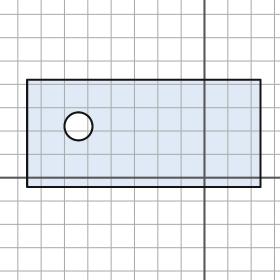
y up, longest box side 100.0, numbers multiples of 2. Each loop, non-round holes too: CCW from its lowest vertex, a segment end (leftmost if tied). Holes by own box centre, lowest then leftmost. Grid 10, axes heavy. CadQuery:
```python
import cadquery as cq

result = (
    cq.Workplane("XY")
    .moveTo(-76.0, -4.0)
    .lineTo(24.0, -4.0)
    .lineTo(24.0, 42.0)
    .lineTo(-76.0, 42.0)
    .close()
    .moveTo(-54.0, 22.0)
    .circle(6.0)
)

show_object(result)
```